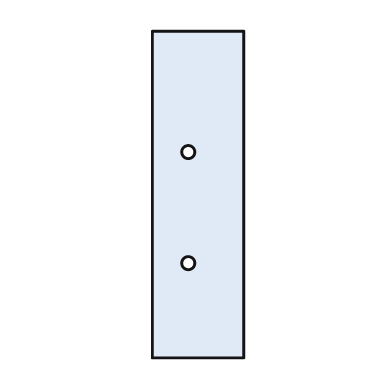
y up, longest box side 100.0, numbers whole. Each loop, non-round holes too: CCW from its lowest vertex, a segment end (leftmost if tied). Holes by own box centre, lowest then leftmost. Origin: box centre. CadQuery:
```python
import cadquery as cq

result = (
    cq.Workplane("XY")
    .moveTo(-14.0, -50.0)
    .lineTo(14.0, -50.0)
    .lineTo(14.0, 50.0)
    .lineTo(-14.0, 50.0)
    .close()
    .moveTo(-3.0, -21.0)
    .circle(2.0)
    .moveTo(-3.0, 13.0)
    .circle(2.0)
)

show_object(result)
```